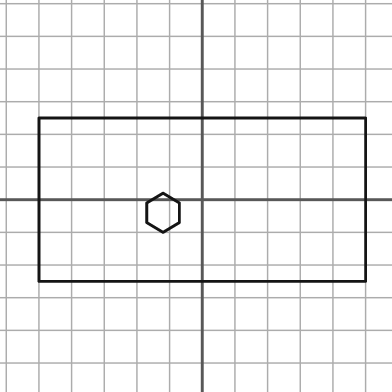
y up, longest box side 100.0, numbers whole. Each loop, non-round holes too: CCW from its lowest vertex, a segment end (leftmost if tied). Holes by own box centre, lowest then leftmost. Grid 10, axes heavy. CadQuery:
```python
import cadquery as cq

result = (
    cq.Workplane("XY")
    .moveTo(-50.0, -25.0)
    .lineTo(50.0, -25.0)
    .lineTo(50.0, 25.0)
    .lineTo(-50.0, 25.0)
    .close()
    .moveTo(-12.0, -10.0)
    .lineTo(-7.0, -7.0)
    .lineTo(-7.0, -1.0)
    .lineTo(-12.0, 2.0)
    .lineTo(-17.0, -1.0)
    .lineTo(-17.0, -7.0)
    .close()
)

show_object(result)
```